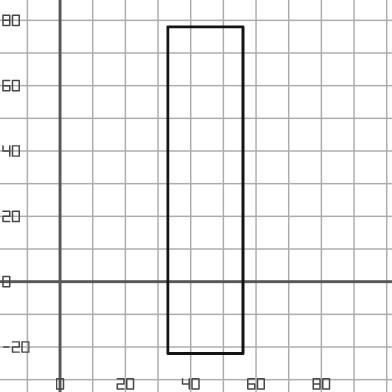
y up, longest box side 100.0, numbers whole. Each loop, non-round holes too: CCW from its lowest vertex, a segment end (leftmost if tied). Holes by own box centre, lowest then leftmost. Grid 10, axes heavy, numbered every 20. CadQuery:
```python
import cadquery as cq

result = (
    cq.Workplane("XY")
    .moveTo(33.0, -22.0)
    .lineTo(56.0, -22.0)
    .lineTo(56.0, 78.0)
    .lineTo(33.0, 78.0)
    .close()
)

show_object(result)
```